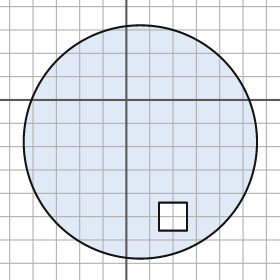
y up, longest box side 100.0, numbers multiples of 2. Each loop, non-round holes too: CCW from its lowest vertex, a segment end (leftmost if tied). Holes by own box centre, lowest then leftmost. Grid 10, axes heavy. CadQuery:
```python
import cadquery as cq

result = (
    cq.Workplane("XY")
    .moveTo(6.0, -18.0)
    .circle(50.0)
    .moveTo(14.0, -56.0)
    .lineTo(26.0, -56.0)
    .lineTo(26.0, -44.0)
    .lineTo(14.0, -44.0)
    .close()
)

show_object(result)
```